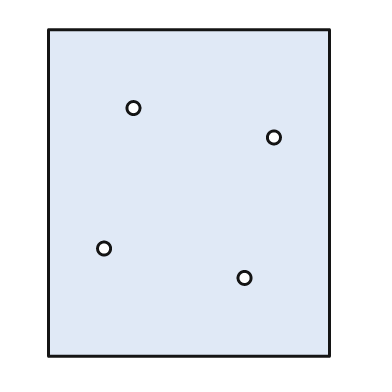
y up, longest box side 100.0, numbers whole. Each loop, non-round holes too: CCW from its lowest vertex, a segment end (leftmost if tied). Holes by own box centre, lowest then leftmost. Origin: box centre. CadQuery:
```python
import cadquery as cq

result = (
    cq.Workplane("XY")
    .moveTo(-43.0, -50.0)
    .lineTo(43.0, -50.0)
    .lineTo(43.0, 50.0)
    .lineTo(-43.0, 50.0)
    .close()
    .moveTo(17.0, -26.0)
    .circle(2.0)
    .moveTo(-26.0, -17.0)
    .circle(2.0)
    .moveTo(26.0, 17.0)
    .circle(2.0)
    .moveTo(-17.0, 26.0)
    .circle(2.0)
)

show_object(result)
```